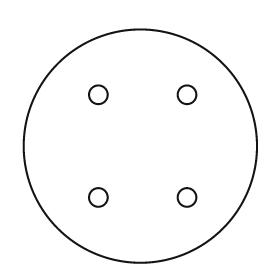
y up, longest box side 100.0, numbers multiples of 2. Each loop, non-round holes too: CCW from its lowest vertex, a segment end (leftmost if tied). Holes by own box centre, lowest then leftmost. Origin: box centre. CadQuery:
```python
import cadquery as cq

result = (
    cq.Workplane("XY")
    .moveTo(0.0, 0.0)
    .circle(50.0)
    .moveTo(-18.0, -22.0)
    .circle(4.0)
    .moveTo(20.0, -22.0)
    .circle(4.0)
    .moveTo(-18.0, 22.0)
    .circle(4.0)
    .moveTo(20.0, 22.0)
    .circle(4.0)
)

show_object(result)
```